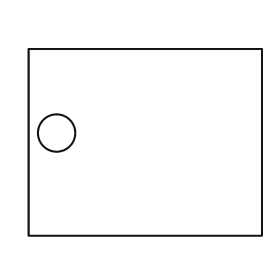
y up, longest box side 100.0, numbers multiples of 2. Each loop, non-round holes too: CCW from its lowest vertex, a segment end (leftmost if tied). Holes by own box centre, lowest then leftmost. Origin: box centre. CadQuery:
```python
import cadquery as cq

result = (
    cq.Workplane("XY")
    .moveTo(-50.0, -40.0)
    .lineTo(50.0, -40.0)
    .lineTo(50.0, 40.0)
    .lineTo(-50.0, 40.0)
    .close()
    .moveTo(-38.0, 4.0)
    .circle(8.0)
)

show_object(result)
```